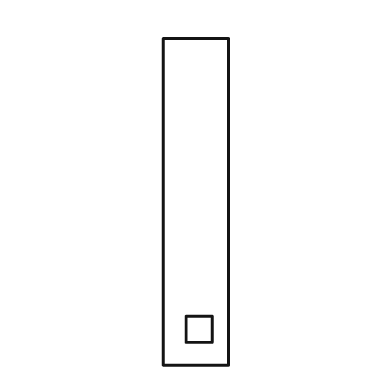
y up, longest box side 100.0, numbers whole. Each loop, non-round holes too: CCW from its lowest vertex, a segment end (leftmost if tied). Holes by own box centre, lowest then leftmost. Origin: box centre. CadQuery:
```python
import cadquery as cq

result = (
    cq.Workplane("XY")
    .moveTo(-10.0, -50.0)
    .lineTo(10.0, -50.0)
    .lineTo(10.0, 50.0)
    .lineTo(-10.0, 50.0)
    .close()
    .moveTo(-3.0, -43.0)
    .lineTo(5.0, -43.0)
    .lineTo(5.0, -35.0)
    .lineTo(-3.0, -35.0)
    .close()
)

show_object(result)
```